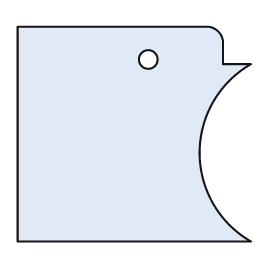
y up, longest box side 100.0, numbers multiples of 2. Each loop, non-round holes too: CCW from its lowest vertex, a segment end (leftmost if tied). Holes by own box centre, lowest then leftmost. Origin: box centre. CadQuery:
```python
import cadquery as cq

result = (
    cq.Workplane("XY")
    .moveTo(-50.0, -46.0)
    .lineTo(50.0, -46.0)
    .threePointArc((28.0, -8.0), (50.0, 30.0))
    .lineTo(38.0, 30.0)
    .lineTo(38.0, 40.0)
    .threePointArc((36.0, 44.0), (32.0, 46.0))
    .lineTo(-50.0, 46.0)
    .close()
    .moveTo(6.0, 32.0)
    .circle(4.0)
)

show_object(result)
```